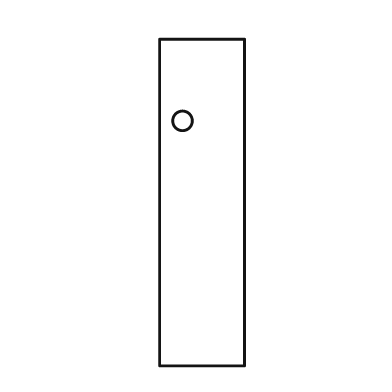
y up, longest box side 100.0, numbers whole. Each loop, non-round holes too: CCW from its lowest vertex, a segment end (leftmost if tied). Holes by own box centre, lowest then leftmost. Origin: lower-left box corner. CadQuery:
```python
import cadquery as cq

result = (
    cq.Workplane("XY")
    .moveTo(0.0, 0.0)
    .lineTo(26.0, 0.0)
    .lineTo(26.0, 100.0)
    .lineTo(0.0, 100.0)
    .close()
    .moveTo(7.0, 75.0)
    .circle(3.0)
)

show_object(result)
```